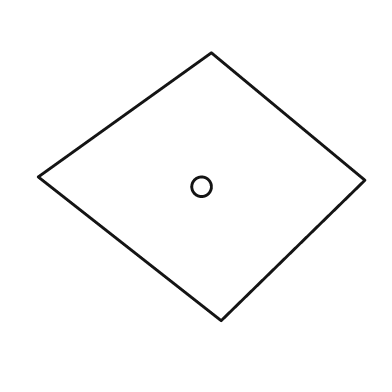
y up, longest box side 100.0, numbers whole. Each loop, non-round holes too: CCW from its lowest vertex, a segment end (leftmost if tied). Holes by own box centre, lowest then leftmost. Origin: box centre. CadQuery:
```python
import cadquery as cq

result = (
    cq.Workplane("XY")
    .moveTo(6.0, -41.0)
    .lineTo(50.0, 2.0)
    .lineTo(3.0, 41.0)
    .lineTo(-50.0, 3.0)
    .close()
    .moveTo(0.0, 0.0)
    .circle(3.0)
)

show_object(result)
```